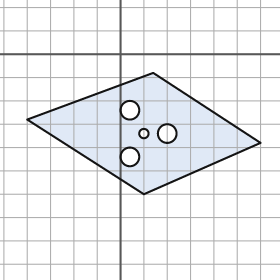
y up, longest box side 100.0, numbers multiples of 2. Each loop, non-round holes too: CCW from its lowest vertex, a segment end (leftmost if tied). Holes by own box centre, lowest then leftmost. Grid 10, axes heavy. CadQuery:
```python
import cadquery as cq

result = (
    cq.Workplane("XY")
    .moveTo(10.0, -60.0)
    .lineTo(60.0, -38.0)
    .lineTo(14.0, -8.0)
    .lineTo(-40.0, -28.0)
    .close()
    .moveTo(4.0, -44.0)
    .circle(4.0)
    .moveTo(10.0, -34.0)
    .circle(2.0)
    .moveTo(20.0, -34.0)
    .circle(4.0)
    .moveTo(4.0, -24.0)
    .circle(4.0)
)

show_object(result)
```